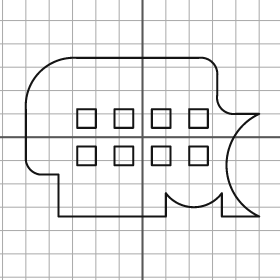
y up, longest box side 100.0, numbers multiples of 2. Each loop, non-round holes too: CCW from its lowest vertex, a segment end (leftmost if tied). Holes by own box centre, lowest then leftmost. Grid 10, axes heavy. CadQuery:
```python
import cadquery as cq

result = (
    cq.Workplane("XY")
    .moveTo(-36.0, -34.0)
    .lineTo(10.0, -34.0)
    .lineTo(10.0, -24.0)
    .threePointArc((22.0, -30.0), (34.0, -24.0))
    .lineTo(34.0, -34.0)
    .lineTo(50.0, -34.0)
    .threePointArc((36.0, -12.0), (50.0, 10.0))
    .lineTo(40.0, 10.0)
    .threePointArc((34.0, 12.0), (32.0, 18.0))
    .lineTo(32.0, 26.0)
    .threePointArc((30.0, 32.0), (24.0, 34.0))
    .lineTo(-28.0, 34.0)
    .threePointArc((-44.0, 28.0), (-50.0, 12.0))
    .lineTo(-50.0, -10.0)
    .threePointArc((-48.0, -14.0), (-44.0, -16.0))
    .lineTo(-36.0, -16.0)
    .close()
    .moveTo(-28.0, -12.0)
    .lineTo(-20.0, -12.0)
    .lineTo(-20.0, -4.0)
    .lineTo(-28.0, -4.0)
    .close()
    .moveTo(-12.0, -12.0)
    .lineTo(-4.0, -12.0)
    .lineTo(-4.0, -4.0)
    .lineTo(-12.0, -4.0)
    .close()
    .moveTo(4.0, -12.0)
    .lineTo(12.0, -12.0)
    .lineTo(12.0, -4.0)
    .lineTo(4.0, -4.0)
    .close()
    .moveTo(20.0, -12.0)
    .lineTo(28.0, -12.0)
    .lineTo(28.0, -4.0)
    .lineTo(20.0, -4.0)
    .close()
    .moveTo(-28.0, 4.0)
    .lineTo(-20.0, 4.0)
    .lineTo(-20.0, 12.0)
    .lineTo(-28.0, 12.0)
    .close()
    .moveTo(-12.0, 4.0)
    .lineTo(-4.0, 4.0)
    .lineTo(-4.0, 12.0)
    .lineTo(-12.0, 12.0)
    .close()
    .moveTo(4.0, 4.0)
    .lineTo(12.0, 4.0)
    .lineTo(12.0, 12.0)
    .lineTo(4.0, 12.0)
    .close()
    .moveTo(20.0, 4.0)
    .lineTo(28.0, 4.0)
    .lineTo(28.0, 12.0)
    .lineTo(20.0, 12.0)
    .close()
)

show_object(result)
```